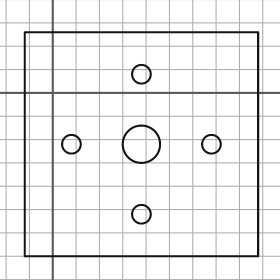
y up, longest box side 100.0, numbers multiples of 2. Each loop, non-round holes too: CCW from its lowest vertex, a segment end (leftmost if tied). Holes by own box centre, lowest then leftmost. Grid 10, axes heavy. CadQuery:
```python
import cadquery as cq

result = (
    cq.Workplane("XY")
    .moveTo(-12.0, -70.0)
    .lineTo(88.0, -70.0)
    .lineTo(88.0, 26.0)
    .lineTo(-12.0, 26.0)
    .close()
    .moveTo(38.0, -52.0)
    .circle(4.0)
    .moveTo(8.0, -22.0)
    .circle(4.0)
    .moveTo(38.0, -22.0)
    .circle(8.0)
    .moveTo(68.0, -22.0)
    .circle(4.0)
    .moveTo(38.0, 8.0)
    .circle(4.0)
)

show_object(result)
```